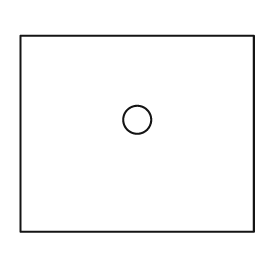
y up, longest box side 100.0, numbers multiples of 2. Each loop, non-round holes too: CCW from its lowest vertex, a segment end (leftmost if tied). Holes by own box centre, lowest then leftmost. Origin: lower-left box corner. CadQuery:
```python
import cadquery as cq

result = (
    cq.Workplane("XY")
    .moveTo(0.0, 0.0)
    .lineTo(100.0, 0.0)
    .lineTo(100.0, 84.0)
    .lineTo(0.0, 84.0)
    .close()
    .moveTo(50.0, 48.0)
    .circle(6.0)
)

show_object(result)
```